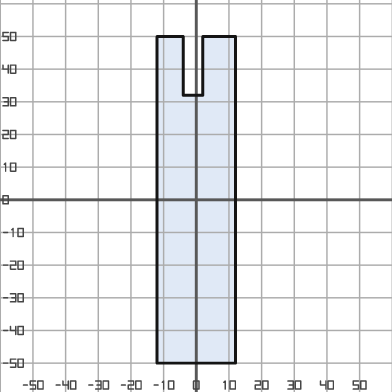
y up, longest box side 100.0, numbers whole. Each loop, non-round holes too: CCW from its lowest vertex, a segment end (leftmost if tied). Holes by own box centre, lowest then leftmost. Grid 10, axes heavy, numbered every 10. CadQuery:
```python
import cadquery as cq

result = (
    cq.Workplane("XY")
    .moveTo(-12.0, -50.0)
    .lineTo(12.0, -50.0)
    .lineTo(12.0, 50.0)
    .lineTo(2.0, 50.0)
    .lineTo(2.0, 32.0)
    .lineTo(-4.0, 32.0)
    .lineTo(-4.0, 50.0)
    .lineTo(-12.0, 50.0)
    .close()
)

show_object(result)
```